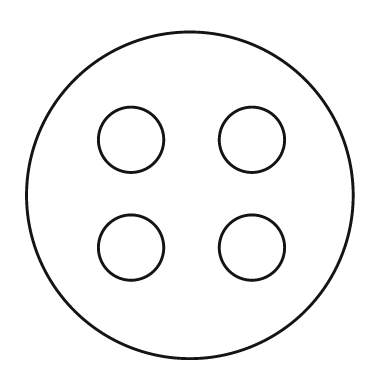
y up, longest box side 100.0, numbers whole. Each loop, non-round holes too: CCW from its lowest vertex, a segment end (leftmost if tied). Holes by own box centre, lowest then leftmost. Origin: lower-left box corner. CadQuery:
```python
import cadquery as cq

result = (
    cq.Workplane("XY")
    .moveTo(50.0, 50.0)
    .circle(50.0)
    .moveTo(32.0, 34.0)
    .circle(10.0)
    .moveTo(69.0, 34.0)
    .circle(10.0)
    .moveTo(32.0, 67.0)
    .circle(10.0)
    .moveTo(69.0, 67.0)
    .circle(10.0)
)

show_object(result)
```